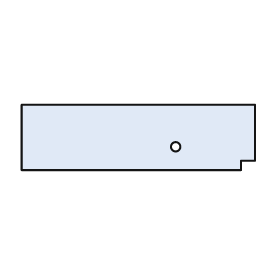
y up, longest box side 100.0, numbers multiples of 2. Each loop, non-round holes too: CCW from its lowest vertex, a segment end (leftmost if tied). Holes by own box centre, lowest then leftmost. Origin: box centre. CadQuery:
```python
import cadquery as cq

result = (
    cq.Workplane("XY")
    .moveTo(-50.0, -14.0)
    .lineTo(44.0, -14.0)
    .lineTo(44.0, -10.0)
    .lineTo(50.0, -10.0)
    .lineTo(50.0, 14.0)
    .lineTo(-50.0, 14.0)
    .close()
    .moveTo(16.0, -4.0)
    .circle(2.0)
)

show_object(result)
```